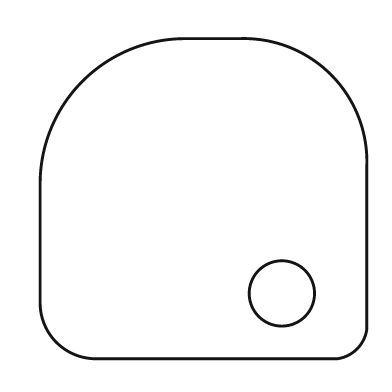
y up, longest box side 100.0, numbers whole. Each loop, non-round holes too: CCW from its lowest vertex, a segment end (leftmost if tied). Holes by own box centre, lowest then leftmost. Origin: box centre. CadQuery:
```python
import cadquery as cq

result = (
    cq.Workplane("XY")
    .moveTo(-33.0, -49.0)
    .lineTo(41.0, -49.0)
    .threePointArc((47.0, -46.0), (50.0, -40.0))
    .lineTo(50.0, 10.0)
    .threePointArc((39.0, 38.0), (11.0, 49.0))
    .lineTo(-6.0, 49.0)
    .threePointArc((-37.0, 36.0), (-50.0, 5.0))
    .lineTo(-50.0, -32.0)
    .threePointArc((-45.0, -44.0), (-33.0, -49.0))
    .close()
    .moveTo(24.0, -29.0)
    .circle(10.0)
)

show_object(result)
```